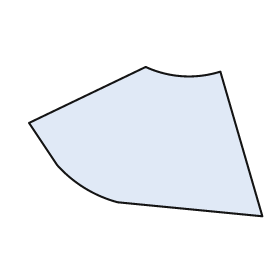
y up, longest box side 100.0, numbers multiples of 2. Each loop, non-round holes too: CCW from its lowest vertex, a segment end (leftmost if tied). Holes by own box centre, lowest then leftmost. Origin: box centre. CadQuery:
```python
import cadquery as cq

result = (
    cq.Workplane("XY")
    .moveTo(50.0, -32.0)
    .lineTo(32.0, 30.0)
    .threePointArc((16.0, 28.0), (0.0, 32.0))
    .lineTo(-50.0, 8.0)
    .lineTo(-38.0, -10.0)
    .threePointArc((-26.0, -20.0), (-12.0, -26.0))
    .close()
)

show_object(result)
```